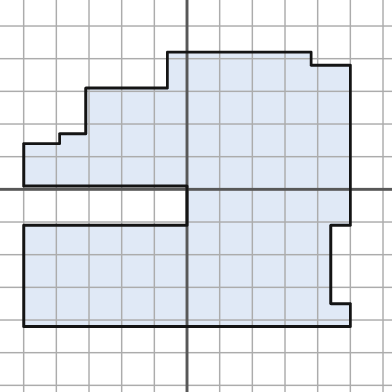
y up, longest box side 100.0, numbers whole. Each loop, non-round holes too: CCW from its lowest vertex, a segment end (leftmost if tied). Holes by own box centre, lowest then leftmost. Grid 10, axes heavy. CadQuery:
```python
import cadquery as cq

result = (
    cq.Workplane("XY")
    .moveTo(-50.0, -42.0)
    .lineTo(50.0, -42.0)
    .lineTo(50.0, -35.0)
    .lineTo(44.0, -35.0)
    .lineTo(44.0, -11.0)
    .lineTo(50.0, -11.0)
    .lineTo(50.0, 38.0)
    .lineTo(38.0, 38.0)
    .lineTo(38.0, 42.0)
    .lineTo(-6.0, 42.0)
    .lineTo(-6.0, 31.0)
    .lineTo(-31.0, 31.0)
    .lineTo(-31.0, 17.0)
    .lineTo(-39.0, 17.0)
    .lineTo(-39.0, 14.0)
    .lineTo(-50.0, 14.0)
    .lineTo(-50.0, 1.0)
    .lineTo(0.0, 1.0)
    .lineTo(0.0, -11.0)
    .lineTo(-50.0, -11.0)
    .close()
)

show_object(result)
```